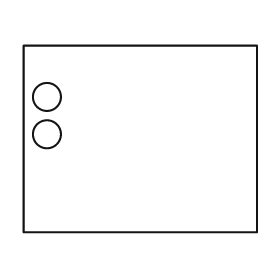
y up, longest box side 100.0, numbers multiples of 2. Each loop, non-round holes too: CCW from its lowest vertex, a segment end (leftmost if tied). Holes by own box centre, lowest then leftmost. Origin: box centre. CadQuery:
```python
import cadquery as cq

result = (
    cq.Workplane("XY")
    .moveTo(-50.0, -40.0)
    .lineTo(50.0, -40.0)
    .lineTo(50.0, 40.0)
    .lineTo(-50.0, 40.0)
    .close()
    .moveTo(-40.0, 2.0)
    .circle(6.0)
    .moveTo(-40.0, 18.0)
    .circle(6.0)
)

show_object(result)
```